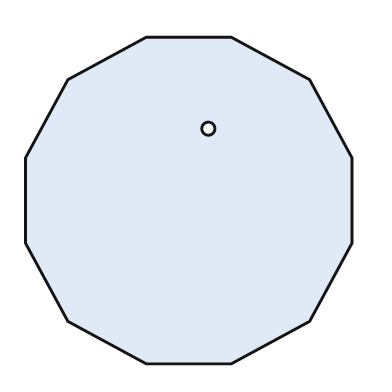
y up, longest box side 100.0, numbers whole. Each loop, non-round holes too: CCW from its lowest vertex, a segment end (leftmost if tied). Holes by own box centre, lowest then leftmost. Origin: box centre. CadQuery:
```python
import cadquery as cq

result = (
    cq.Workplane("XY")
    .moveTo(-13.0, -50.0)
    .lineTo(13.0, -50.0)
    .lineTo(37.0, -37.0)
    .lineTo(50.0, -13.0)
    .lineTo(50.0, 13.0)
    .lineTo(37.0, 37.0)
    .lineTo(13.0, 50.0)
    .lineTo(-13.0, 50.0)
    .lineTo(-37.0, 37.0)
    .lineTo(-50.0, 13.0)
    .lineTo(-50.0, -13.0)
    .lineTo(-37.0, -37.0)
    .close()
    .moveTo(6.0, 22.0)
    .circle(2.0)
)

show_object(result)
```